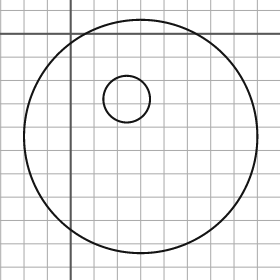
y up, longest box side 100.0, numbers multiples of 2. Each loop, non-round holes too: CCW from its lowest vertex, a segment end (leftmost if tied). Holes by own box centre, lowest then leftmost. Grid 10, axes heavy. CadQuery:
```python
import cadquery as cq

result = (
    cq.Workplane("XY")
    .moveTo(30.0, -44.0)
    .circle(50.0)
    .moveTo(24.0, -28.0)
    .circle(10.0)
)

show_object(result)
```